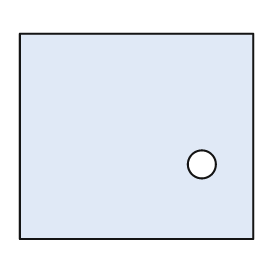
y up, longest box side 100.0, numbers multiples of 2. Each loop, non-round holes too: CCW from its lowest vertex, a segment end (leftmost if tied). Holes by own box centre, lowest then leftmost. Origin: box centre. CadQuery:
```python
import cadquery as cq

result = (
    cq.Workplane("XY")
    .moveTo(-50.0, -44.0)
    .lineTo(50.0, -44.0)
    .lineTo(50.0, 44.0)
    .lineTo(-50.0, 44.0)
    .close()
    .moveTo(28.0, -12.0)
    .circle(6.0)
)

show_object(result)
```